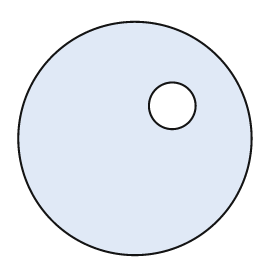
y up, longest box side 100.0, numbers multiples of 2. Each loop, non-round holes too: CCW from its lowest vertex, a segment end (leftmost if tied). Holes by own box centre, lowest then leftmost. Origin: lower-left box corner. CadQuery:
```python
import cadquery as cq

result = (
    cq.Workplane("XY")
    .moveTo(50.0, 50.0)
    .circle(50.0)
    .moveTo(66.0, 64.0)
    .circle(10.0)
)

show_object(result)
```